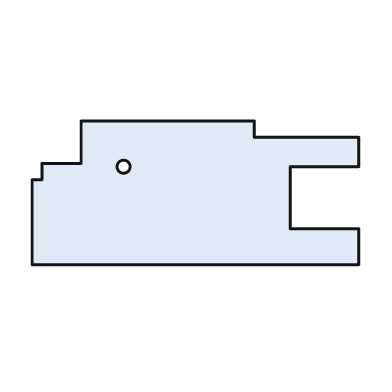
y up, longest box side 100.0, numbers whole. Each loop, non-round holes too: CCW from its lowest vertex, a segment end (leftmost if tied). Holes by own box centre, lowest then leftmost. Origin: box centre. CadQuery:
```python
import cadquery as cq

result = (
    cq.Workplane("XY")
    .moveTo(-50.0, -22.0)
    .lineTo(50.0, -22.0)
    .lineTo(50.0, -11.0)
    .lineTo(29.0, -11.0)
    .lineTo(29.0, 8.0)
    .lineTo(50.0, 8.0)
    .lineTo(50.0, 17.0)
    .lineTo(18.0, 17.0)
    .lineTo(18.0, 22.0)
    .lineTo(-35.0, 22.0)
    .lineTo(-35.0, 9.0)
    .lineTo(-47.0, 9.0)
    .lineTo(-47.0, 4.0)
    .lineTo(-50.0, 4.0)
    .close()
    .moveTo(-22.0, 8.0)
    .circle(2.0)
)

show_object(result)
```